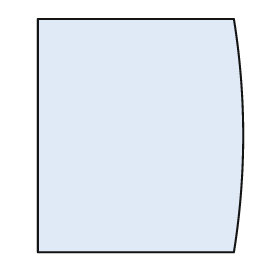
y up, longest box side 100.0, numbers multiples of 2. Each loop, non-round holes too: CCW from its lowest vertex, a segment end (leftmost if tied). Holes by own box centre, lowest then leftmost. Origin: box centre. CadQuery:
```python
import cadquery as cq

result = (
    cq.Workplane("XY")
    .moveTo(-44.0, -50.0)
    .lineTo(40.0, -50.0)
    .threePointArc((44.0, 0.0), (40.0, 50.0))
    .lineTo(-44.0, 50.0)
    .close()
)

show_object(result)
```